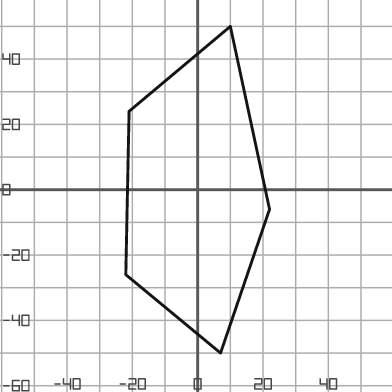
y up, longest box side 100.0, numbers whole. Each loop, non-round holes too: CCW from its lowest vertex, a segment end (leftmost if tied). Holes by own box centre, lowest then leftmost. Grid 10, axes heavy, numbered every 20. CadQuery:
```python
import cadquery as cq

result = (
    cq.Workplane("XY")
    .moveTo(7.0, -50.0)
    .lineTo(22.0, -6.0)
    .lineTo(10.0, 50.0)
    .lineTo(-21.0, 24.0)
    .lineTo(-22.0, -26.0)
    .close()
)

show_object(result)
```